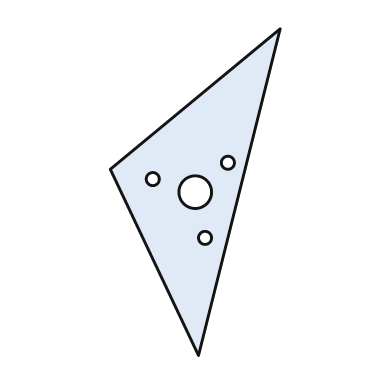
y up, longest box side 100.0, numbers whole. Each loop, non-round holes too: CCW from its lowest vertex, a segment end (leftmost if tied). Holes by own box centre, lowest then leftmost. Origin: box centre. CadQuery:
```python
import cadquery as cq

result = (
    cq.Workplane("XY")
    .moveTo(1.0, -50.0)
    .lineTo(26.0, 50.0)
    .lineTo(-26.0, 7.0)
    .close()
    .moveTo(3.0, -14.0)
    .circle(2.0)
    .moveTo(0.0, 0.0)
    .circle(5.0)
    .moveTo(-13.0, 4.0)
    .circle(2.0)
    .moveTo(10.0, 9.0)
    .circle(2.0)
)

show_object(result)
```